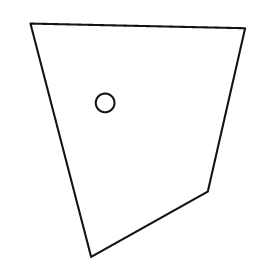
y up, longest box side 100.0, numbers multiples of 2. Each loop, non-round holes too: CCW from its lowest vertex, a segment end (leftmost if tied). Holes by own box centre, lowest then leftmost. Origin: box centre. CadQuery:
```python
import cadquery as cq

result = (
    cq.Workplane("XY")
    .moveTo(-20.0, -50.0)
    .lineTo(30.0, -22.0)
    .lineTo(46.0, 48.0)
    .lineTo(-46.0, 50.0)
    .close()
    .moveTo(-14.0, 16.0)
    .circle(4.0)
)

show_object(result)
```